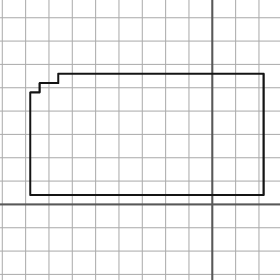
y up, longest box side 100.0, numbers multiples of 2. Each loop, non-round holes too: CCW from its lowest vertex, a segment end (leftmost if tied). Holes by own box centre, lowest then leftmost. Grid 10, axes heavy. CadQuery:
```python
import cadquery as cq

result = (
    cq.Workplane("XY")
    .moveTo(-78.0, 4.0)
    .lineTo(22.0, 4.0)
    .lineTo(22.0, 56.0)
    .lineTo(-66.0, 56.0)
    .lineTo(-66.0, 52.0)
    .lineTo(-74.0, 52.0)
    .lineTo(-74.0, 48.0)
    .lineTo(-78.0, 48.0)
    .close()
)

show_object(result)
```